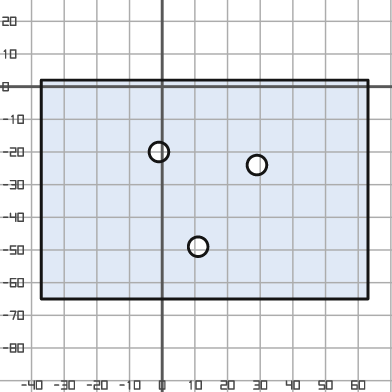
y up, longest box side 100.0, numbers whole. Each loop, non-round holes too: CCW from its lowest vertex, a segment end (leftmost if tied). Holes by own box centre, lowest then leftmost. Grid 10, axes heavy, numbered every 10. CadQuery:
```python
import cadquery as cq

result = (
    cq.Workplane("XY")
    .moveTo(-37.0, -65.0)
    .lineTo(63.0, -65.0)
    .lineTo(63.0, 2.0)
    .lineTo(-37.0, 2.0)
    .close()
    .moveTo(11.0, -49.0)
    .circle(3.0)
    .moveTo(29.0, -24.0)
    .circle(3.0)
    .moveTo(-1.0, -20.0)
    .circle(3.0)
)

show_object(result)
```